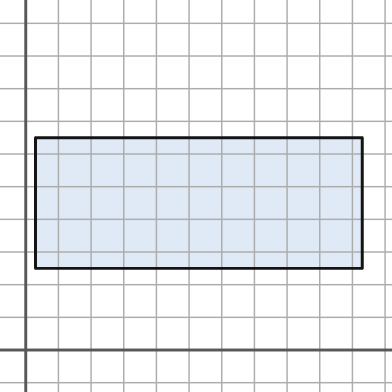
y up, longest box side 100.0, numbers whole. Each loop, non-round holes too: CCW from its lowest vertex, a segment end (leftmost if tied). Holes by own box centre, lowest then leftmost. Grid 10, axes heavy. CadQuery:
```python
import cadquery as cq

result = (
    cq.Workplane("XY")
    .moveTo(3.0, 25.0)
    .lineTo(103.0, 25.0)
    .lineTo(103.0, 65.0)
    .lineTo(3.0, 65.0)
    .close()
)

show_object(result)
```